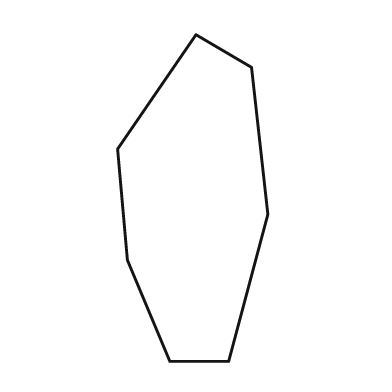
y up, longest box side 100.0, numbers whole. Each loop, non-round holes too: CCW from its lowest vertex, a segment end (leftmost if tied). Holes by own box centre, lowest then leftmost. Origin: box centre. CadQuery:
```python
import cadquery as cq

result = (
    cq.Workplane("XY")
    .moveTo(-7.0, -50.0)
    .lineTo(11.0, -50.0)
    .lineTo(23.0, -5.0)
    .lineTo(18.0, 40.0)
    .lineTo(1.0, 50.0)
    .lineTo(-23.0, 15.0)
    .lineTo(-20.0, -19.0)
    .close()
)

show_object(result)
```